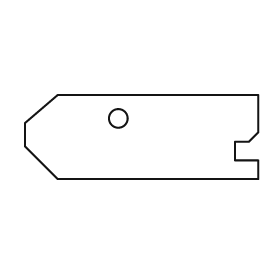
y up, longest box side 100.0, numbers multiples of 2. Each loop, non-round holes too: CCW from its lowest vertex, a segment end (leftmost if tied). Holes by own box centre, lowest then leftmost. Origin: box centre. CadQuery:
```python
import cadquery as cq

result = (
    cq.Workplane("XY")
    .moveTo(-36.0, -18.0)
    .lineTo(50.0, -18.0)
    .lineTo(50.0, -10.0)
    .lineTo(40.0, -10.0)
    .lineTo(40.0, -2.0)
    .lineTo(46.0, -2.0)
    .lineTo(50.0, 2.0)
    .lineTo(50.0, 18.0)
    .lineTo(-36.0, 18.0)
    .lineTo(-50.0, 6.0)
    .lineTo(-50.0, -4.0)
    .close()
    .moveTo(-10.0, 8.0)
    .circle(4.0)
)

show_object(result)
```